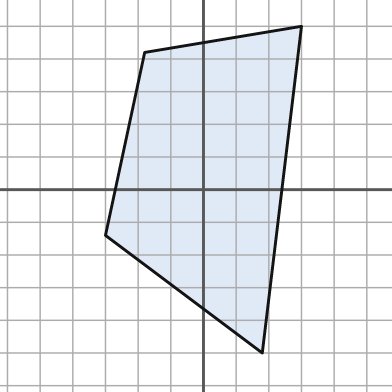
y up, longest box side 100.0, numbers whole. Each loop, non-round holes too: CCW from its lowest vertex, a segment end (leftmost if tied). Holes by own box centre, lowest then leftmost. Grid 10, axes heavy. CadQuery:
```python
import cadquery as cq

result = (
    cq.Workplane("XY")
    .moveTo(18.0, -50.0)
    .lineTo(30.0, 50.0)
    .lineTo(-18.0, 42.0)
    .lineTo(-30.0, -14.0)
    .close()
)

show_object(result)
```